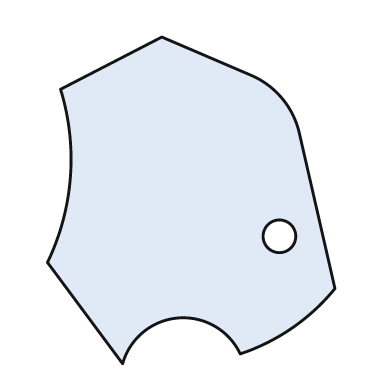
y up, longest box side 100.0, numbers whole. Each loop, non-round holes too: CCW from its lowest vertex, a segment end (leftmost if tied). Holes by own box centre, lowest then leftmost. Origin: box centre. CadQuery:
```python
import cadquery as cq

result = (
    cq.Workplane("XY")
    .moveTo(-21.0, -50.0)
    .threePointArc((-4.0, -36.0), (15.0, -47.0))
    .threePointArc((31.0, -39.0), (44.0, -27.0))
    .lineTo(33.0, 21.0)
    .threePointArc((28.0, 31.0), (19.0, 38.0))
    .lineTo(-9.0, 50.0)
    .lineTo(-40.0, 34.0)
    .threePointArc((-37.0, 7.0), (-44.0, -19.0))
    .close()
    .moveTo(27.0, -11.0)
    .circle(5.0)
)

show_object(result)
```